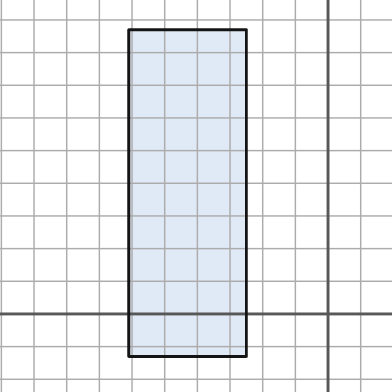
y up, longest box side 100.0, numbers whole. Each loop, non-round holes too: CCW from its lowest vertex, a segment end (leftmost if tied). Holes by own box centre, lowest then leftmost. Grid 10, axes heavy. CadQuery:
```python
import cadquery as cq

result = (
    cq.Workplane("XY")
    .moveTo(-61.0, -13.0)
    .lineTo(-25.0, -13.0)
    .lineTo(-25.0, 87.0)
    .lineTo(-61.0, 87.0)
    .close()
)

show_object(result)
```